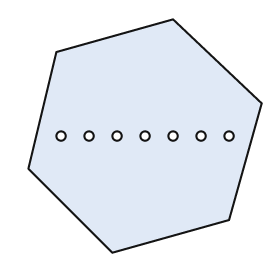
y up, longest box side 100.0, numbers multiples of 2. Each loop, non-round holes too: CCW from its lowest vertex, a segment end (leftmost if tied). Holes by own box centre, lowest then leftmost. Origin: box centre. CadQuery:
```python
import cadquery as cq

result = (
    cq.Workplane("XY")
    .moveTo(-14.0, -50.0)
    .lineTo(36.0, -36.0)
    .lineTo(50.0, 14.0)
    .lineTo(12.0, 50.0)
    .lineTo(-38.0, 36.0)
    .lineTo(-50.0, -14.0)
    .close()
    .moveTo(-36.0, 0.0)
    .circle(2.0)
    .moveTo(-24.0, 0.0)
    .circle(2.0)
    .moveTo(-12.0, 0.0)
    .circle(2.0)
    .moveTo(0.0, 0.0)
    .circle(2.0)
    .moveTo(12.0, 0.0)
    .circle(2.0)
    .moveTo(24.0, 0.0)
    .circle(2.0)
    .moveTo(36.0, 0.0)
    .circle(2.0)
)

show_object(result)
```